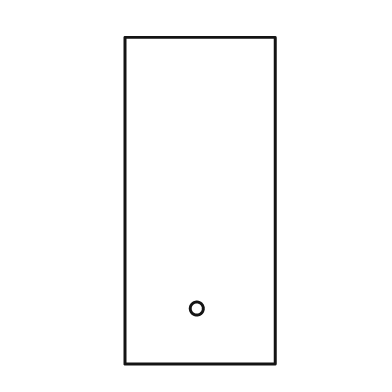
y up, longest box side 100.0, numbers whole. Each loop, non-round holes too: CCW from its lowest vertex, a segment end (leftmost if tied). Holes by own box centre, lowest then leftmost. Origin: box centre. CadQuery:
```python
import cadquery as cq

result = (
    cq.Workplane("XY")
    .moveTo(-23.0, -50.0)
    .lineTo(23.0, -50.0)
    .lineTo(23.0, 50.0)
    .lineTo(-23.0, 50.0)
    .close()
    .moveTo(-1.0, -33.0)
    .circle(2.0)
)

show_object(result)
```